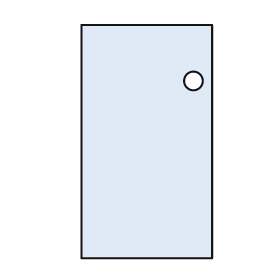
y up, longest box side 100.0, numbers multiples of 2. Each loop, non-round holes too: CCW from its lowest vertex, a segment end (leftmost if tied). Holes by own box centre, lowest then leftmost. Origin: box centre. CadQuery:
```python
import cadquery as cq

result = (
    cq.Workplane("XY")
    .moveTo(-28.0, -50.0)
    .lineTo(28.0, -50.0)
    .lineTo(28.0, 50.0)
    .lineTo(-28.0, 50.0)
    .close()
    .moveTo(20.0, 26.0)
    .circle(4.0)
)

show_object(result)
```